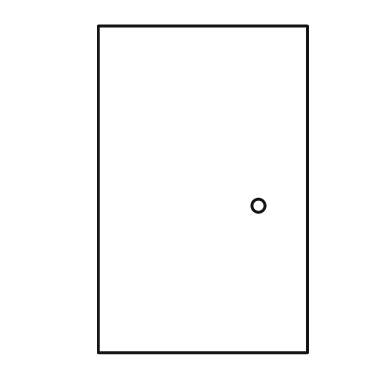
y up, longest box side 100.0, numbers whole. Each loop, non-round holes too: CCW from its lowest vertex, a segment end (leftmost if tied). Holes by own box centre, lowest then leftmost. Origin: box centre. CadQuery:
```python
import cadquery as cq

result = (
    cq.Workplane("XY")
    .moveTo(-32.0, -50.0)
    .lineTo(32.0, -50.0)
    .lineTo(32.0, 50.0)
    .lineTo(-32.0, 50.0)
    .close()
    .moveTo(17.0, -5.0)
    .circle(2.0)
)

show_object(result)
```